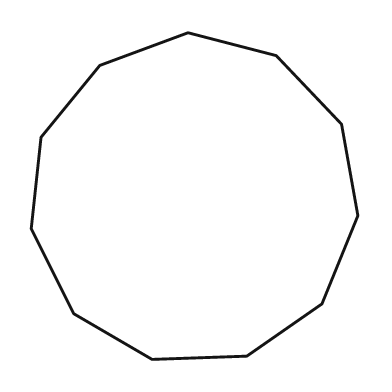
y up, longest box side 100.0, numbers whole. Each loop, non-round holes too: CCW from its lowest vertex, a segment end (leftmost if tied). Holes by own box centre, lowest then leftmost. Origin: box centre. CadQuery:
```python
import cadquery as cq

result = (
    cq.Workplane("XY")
    .moveTo(-13.0, -50.0)
    .lineTo(16.0, -49.0)
    .lineTo(39.0, -33.0)
    .lineTo(50.0, -6.0)
    .lineTo(45.0, 22.0)
    .lineTo(25.0, 43.0)
    .lineTo(-2.0, 50.0)
    .lineTo(-29.0, 40.0)
    .lineTo(-47.0, 18.0)
    .lineTo(-50.0, -10.0)
    .lineTo(-37.0, -36.0)
    .close()
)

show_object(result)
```